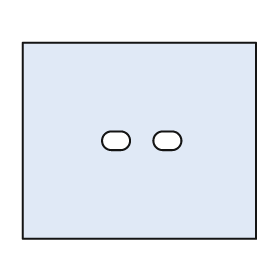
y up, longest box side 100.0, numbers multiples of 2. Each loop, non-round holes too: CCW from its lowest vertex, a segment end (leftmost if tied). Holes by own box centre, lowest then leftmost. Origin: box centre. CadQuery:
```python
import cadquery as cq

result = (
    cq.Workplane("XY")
    .moveTo(-50.0, -42.0)
    .lineTo(50.0, -42.0)
    .lineTo(50.0, 42.0)
    .lineTo(-50.0, 42.0)
    .close()
    .moveTo(-12.0, -4.0)
    .lineTo(-8.0, -4.0)
    .threePointArc((-4.0, 0.0), (-8.0, 4.0))
    .lineTo(-12.0, 4.0)
    .threePointArc((-16.0, 0.0), (-12.0, -4.0))
    .close()
    .moveTo(10.0, -4.0)
    .lineTo(14.0, -4.0)
    .threePointArc((18.0, 0.0), (14.0, 4.0))
    .lineTo(10.0, 4.0)
    .threePointArc((6.0, 0.0), (10.0, -4.0))
    .close()
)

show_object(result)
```